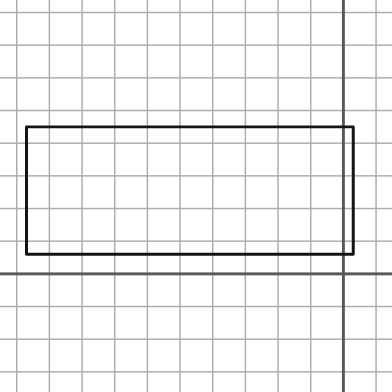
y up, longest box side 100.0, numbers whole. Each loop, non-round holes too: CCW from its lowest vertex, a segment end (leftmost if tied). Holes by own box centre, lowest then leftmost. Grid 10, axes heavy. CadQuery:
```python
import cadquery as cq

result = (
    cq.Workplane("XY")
    .moveTo(-97.0, 6.0)
    .lineTo(3.0, 6.0)
    .lineTo(3.0, 45.0)
    .lineTo(-97.0, 45.0)
    .close()
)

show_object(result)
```